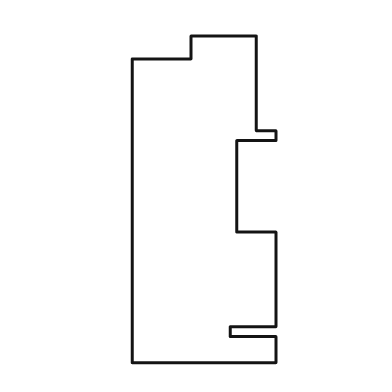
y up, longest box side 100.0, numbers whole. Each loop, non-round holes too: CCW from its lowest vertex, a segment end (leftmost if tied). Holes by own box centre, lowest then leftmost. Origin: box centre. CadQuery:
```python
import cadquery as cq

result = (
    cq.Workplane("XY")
    .moveTo(-22.0, -50.0)
    .lineTo(22.0, -50.0)
    .lineTo(22.0, -42.0)
    .lineTo(8.0, -42.0)
    .lineTo(8.0, -39.0)
    .lineTo(22.0, -39.0)
    .lineTo(22.0, -10.0)
    .lineTo(10.0, -10.0)
    .lineTo(10.0, 18.0)
    .lineTo(22.0, 18.0)
    .lineTo(22.0, 21.0)
    .lineTo(16.0, 21.0)
    .lineTo(16.0, 50.0)
    .lineTo(-4.0, 50.0)
    .lineTo(-4.0, 43.0)
    .lineTo(-22.0, 43.0)
    .close()
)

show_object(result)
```